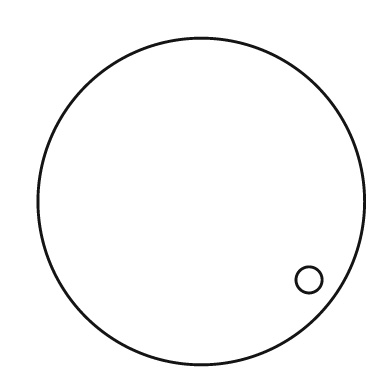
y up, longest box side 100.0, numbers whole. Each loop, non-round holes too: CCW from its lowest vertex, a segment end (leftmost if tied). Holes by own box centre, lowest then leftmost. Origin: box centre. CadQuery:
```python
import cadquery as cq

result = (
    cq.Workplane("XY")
    .moveTo(0.0, 0.0)
    .circle(50.0)
    .moveTo(33.0, -24.0)
    .circle(4.0)
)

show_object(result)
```